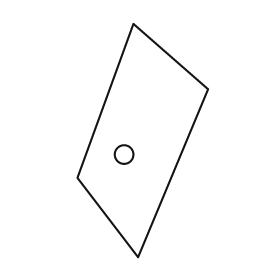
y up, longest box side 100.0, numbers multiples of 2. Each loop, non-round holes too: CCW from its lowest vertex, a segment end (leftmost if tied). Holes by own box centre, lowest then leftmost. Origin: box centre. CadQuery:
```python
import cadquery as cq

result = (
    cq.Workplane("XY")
    .moveTo(-2.0, -50.0)
    .lineTo(28.0, 22.0)
    .lineTo(-4.0, 50.0)
    .lineTo(-28.0, -16.0)
    .close()
    .moveTo(-8.0, -6.0)
    .circle(4.0)
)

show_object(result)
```